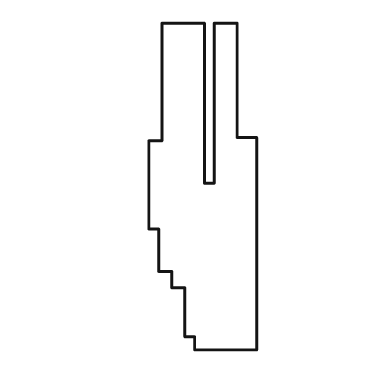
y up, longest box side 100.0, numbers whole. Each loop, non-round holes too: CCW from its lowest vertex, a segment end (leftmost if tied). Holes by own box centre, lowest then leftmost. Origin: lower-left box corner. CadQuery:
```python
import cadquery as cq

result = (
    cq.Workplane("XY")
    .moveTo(14.0, 0.0)
    .lineTo(33.0, 0.0)
    .lineTo(33.0, 65.0)
    .lineTo(27.0, 65.0)
    .lineTo(27.0, 100.0)
    .lineTo(20.0, 100.0)
    .lineTo(20.0, 51.0)
    .lineTo(17.0, 51.0)
    .lineTo(17.0, 100.0)
    .lineTo(4.0, 100.0)
    .lineTo(4.0, 64.0)
    .lineTo(0.0, 64.0)
    .lineTo(0.0, 37.0)
    .lineTo(3.0, 37.0)
    .lineTo(3.0, 24.0)
    .lineTo(7.0, 24.0)
    .lineTo(7.0, 19.0)
    .lineTo(11.0, 19.0)
    .lineTo(11.0, 4.0)
    .lineTo(14.0, 4.0)
    .close()
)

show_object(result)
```